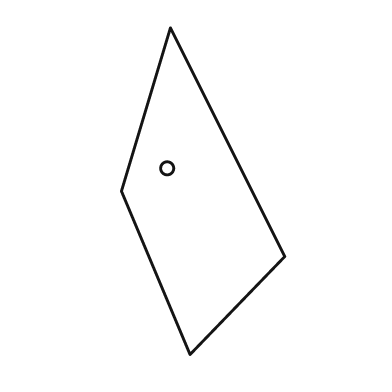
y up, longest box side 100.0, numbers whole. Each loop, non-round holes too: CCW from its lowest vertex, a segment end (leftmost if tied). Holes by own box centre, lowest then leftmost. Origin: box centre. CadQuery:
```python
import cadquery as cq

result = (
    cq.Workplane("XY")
    .moveTo(-4.0, -50.0)
    .lineTo(25.0, -20.0)
    .lineTo(-10.0, 50.0)
    .lineTo(-25.0, 0.0)
    .close()
    .moveTo(-11.0, 7.0)
    .circle(2.0)
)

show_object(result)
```